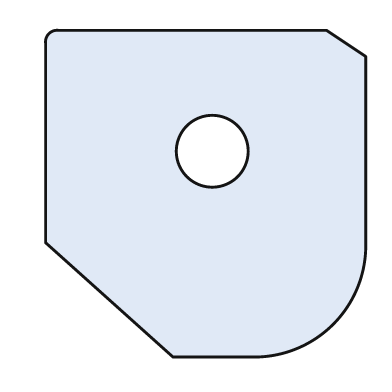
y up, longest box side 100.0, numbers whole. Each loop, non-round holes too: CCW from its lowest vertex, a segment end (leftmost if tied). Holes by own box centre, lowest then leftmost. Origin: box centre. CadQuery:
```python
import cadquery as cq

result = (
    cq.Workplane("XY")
    .moveTo(-10.0, -50.0)
    .lineTo(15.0, -50.0)
    .threePointArc((39.0, -40.0), (49.0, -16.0))
    .lineTo(49.0, 42.0)
    .lineTo(37.0, 50.0)
    .lineTo(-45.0, 50.0)
    .threePointArc((-48.0, 49.0), (-49.0, 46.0))
    .lineTo(-49.0, -15.0)
    .close()
    .moveTo(2.0, 13.0)
    .circle(11.0)
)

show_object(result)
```